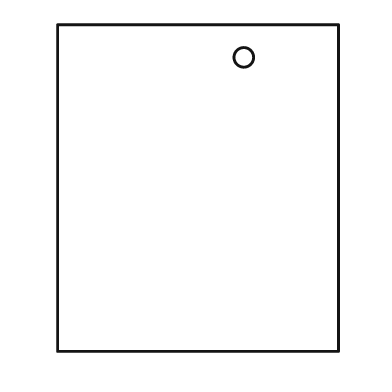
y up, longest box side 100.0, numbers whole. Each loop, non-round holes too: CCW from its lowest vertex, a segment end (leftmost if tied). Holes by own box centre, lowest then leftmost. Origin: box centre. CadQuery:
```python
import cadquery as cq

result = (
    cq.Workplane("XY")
    .moveTo(-43.0, -50.0)
    .lineTo(43.0, -50.0)
    .lineTo(43.0, 50.0)
    .lineTo(-43.0, 50.0)
    .close()
    .moveTo(14.0, 40.0)
    .circle(3.0)
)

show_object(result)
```